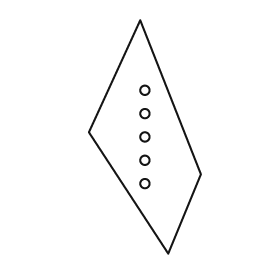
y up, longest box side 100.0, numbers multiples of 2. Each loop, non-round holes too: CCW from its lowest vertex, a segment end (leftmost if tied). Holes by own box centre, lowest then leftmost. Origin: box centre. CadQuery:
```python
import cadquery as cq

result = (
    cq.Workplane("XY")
    .moveTo(10.0, -50.0)
    .lineTo(24.0, -16.0)
    .lineTo(-2.0, 50.0)
    .lineTo(-24.0, 2.0)
    .close()
    .moveTo(0.0, -20.0)
    .circle(2.0)
    .moveTo(0.0, -10.0)
    .circle(2.0)
    .moveTo(0.0, 0.0)
    .circle(2.0)
    .moveTo(0.0, 10.0)
    .circle(2.0)
    .moveTo(0.0, 20.0)
    .circle(2.0)
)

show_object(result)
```